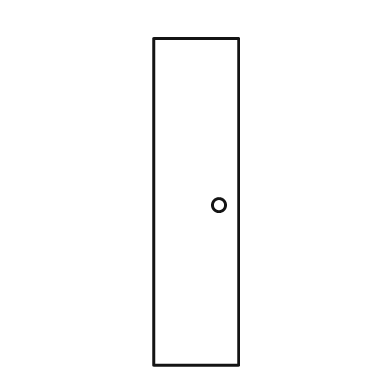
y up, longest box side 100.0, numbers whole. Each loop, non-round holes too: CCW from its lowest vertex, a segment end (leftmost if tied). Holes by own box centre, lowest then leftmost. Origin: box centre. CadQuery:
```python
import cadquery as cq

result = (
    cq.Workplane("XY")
    .moveTo(-13.0, -50.0)
    .lineTo(13.0, -50.0)
    .lineTo(13.0, 50.0)
    .lineTo(-13.0, 50.0)
    .close()
    .moveTo(7.0, -1.0)
    .circle(2.0)
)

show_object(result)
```